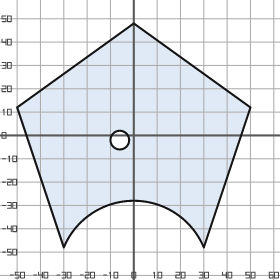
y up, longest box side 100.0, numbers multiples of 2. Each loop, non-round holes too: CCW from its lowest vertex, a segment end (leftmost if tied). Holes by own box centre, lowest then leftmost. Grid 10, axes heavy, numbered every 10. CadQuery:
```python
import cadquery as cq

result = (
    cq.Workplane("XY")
    .moveTo(-30.0, -48.0)
    .threePointArc((0.0, -28.0), (30.0, -48.0))
    .lineTo(50.0, 12.0)
    .lineTo(0.0, 48.0)
    .lineTo(-50.0, 12.0)
    .close()
    .moveTo(-6.0, -2.0)
    .circle(4.0)
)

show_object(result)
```